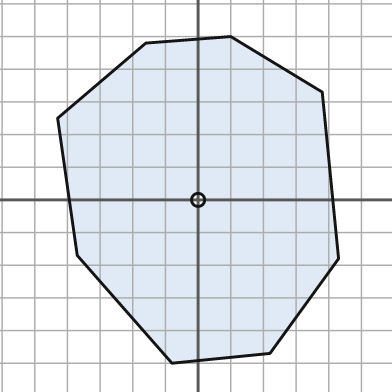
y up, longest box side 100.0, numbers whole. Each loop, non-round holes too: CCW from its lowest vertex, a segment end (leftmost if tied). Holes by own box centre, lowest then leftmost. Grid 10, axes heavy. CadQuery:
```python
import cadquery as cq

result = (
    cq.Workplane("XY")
    .moveTo(-8.0, -50.0)
    .lineTo(22.0, -47.0)
    .lineTo(43.0, -18.0)
    .lineTo(38.0, 33.0)
    .lineTo(10.0, 50.0)
    .lineTo(-16.0, 48.0)
    .lineTo(-43.0, 25.0)
    .lineTo(-37.0, -17.0)
    .close()
    .moveTo(0.0, 0.0)
    .circle(2.0)
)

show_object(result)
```